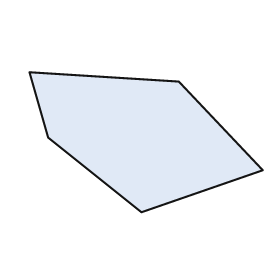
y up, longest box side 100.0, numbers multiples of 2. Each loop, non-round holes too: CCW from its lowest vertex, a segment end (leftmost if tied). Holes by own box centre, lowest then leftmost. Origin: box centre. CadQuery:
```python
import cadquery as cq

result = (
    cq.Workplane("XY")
    .moveTo(-2.0, -30.0)
    .lineTo(50.0, -12.0)
    .lineTo(14.0, 26.0)
    .lineTo(-50.0, 30.0)
    .lineTo(-42.0, 2.0)
    .close()
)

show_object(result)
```